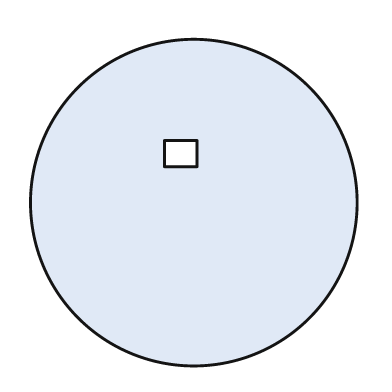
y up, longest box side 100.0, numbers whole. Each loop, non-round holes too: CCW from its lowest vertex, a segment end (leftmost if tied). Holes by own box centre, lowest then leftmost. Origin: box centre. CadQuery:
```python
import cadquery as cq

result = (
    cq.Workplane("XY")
    .moveTo(0.0, 0.0)
    .circle(50.0)
    .moveTo(-9.0, 11.0)
    .lineTo(1.0, 11.0)
    .lineTo(1.0, 19.0)
    .lineTo(-9.0, 19.0)
    .close()
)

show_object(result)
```